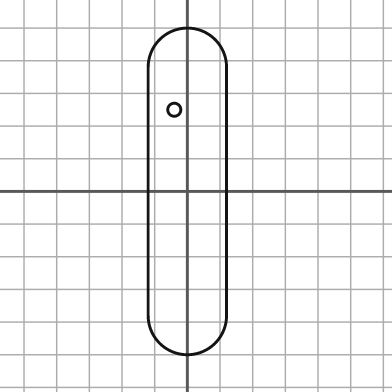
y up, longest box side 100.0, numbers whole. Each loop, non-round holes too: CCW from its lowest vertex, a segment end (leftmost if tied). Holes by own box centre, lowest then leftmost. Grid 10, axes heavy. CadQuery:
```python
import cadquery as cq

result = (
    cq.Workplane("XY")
    .moveTo(-12.0, -38.0)
    .threePointArc((0.0, -50.0), (12.0, -38.0))
    .lineTo(12.0, 38.0)
    .threePointArc((0.0, 50.0), (-12.0, 38.0))
    .close()
    .moveTo(-4.0, 25.0)
    .circle(2.0)
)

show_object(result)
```